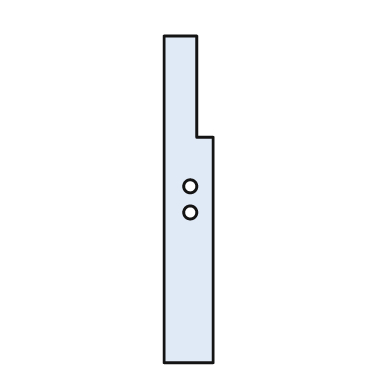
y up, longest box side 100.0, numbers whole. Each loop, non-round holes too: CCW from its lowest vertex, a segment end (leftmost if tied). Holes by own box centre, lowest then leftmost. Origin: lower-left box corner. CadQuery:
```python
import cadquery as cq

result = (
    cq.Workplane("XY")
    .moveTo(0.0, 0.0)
    .lineTo(15.0, 0.0)
    .lineTo(15.0, 69.0)
    .lineTo(10.0, 69.0)
    .lineTo(10.0, 100.0)
    .lineTo(0.0, 100.0)
    .close()
    .moveTo(8.0, 46.0)
    .circle(2.0)
    .moveTo(8.0, 54.0)
    .circle(2.0)
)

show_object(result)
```